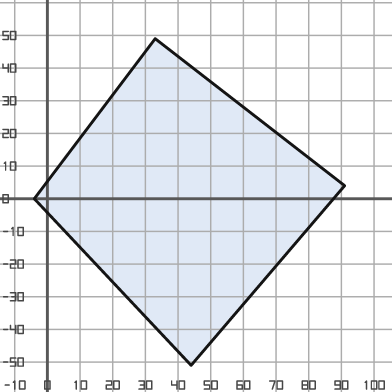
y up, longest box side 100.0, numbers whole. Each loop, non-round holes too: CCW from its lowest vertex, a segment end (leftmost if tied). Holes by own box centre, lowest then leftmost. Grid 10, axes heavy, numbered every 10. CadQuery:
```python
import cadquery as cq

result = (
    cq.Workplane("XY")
    .moveTo(44.0, -51.0)
    .lineTo(91.0, 4.0)
    .lineTo(33.0, 49.0)
    .lineTo(-4.0, 0.0)
    .close()
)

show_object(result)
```